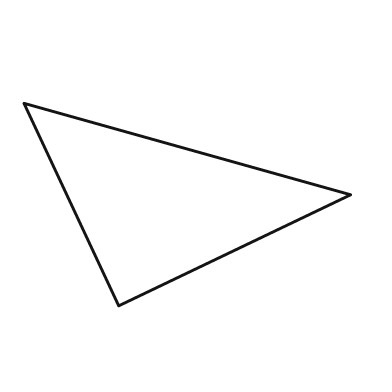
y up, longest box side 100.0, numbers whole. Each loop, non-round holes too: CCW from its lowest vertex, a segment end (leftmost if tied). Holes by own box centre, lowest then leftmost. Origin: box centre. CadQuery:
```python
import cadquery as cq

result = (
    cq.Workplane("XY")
    .moveTo(-21.0, -31.0)
    .lineTo(50.0, 3.0)
    .lineTo(-50.0, 31.0)
    .close()
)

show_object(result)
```